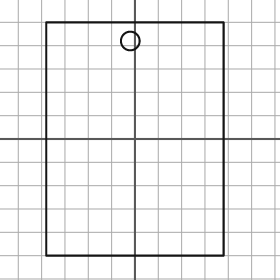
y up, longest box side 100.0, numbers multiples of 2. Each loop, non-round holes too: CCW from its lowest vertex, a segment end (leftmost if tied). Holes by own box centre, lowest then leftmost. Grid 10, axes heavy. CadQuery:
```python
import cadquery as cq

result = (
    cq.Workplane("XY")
    .moveTo(-38.0, -50.0)
    .lineTo(38.0, -50.0)
    .lineTo(38.0, 50.0)
    .lineTo(-38.0, 50.0)
    .close()
    .moveTo(-2.0, 42.0)
    .circle(4.0)
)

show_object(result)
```